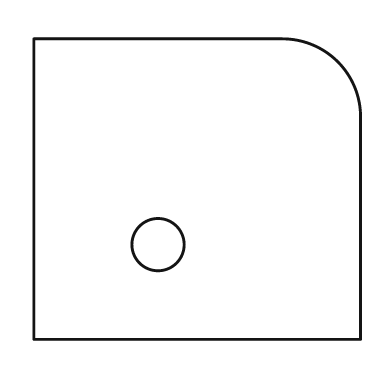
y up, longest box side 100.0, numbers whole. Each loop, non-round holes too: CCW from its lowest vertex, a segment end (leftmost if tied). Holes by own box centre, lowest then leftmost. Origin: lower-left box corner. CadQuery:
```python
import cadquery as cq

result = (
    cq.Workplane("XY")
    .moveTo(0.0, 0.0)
    .lineTo(100.0, 0.0)
    .lineTo(100.0, 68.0)
    .threePointArc((93.0, 85.0), (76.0, 92.0))
    .lineTo(0.0, 92.0)
    .close()
    .moveTo(38.0, 29.0)
    .circle(8.0)
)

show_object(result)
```